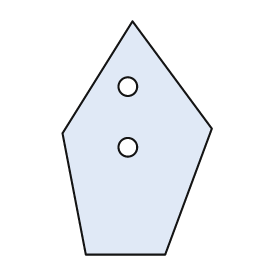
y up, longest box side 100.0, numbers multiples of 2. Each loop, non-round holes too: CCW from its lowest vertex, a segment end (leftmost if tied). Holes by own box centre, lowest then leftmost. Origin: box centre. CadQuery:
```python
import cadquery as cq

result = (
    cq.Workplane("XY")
    .moveTo(-22.0, -50.0)
    .lineTo(12.0, -50.0)
    .lineTo(32.0, 4.0)
    .lineTo(-2.0, 50.0)
    .lineTo(-32.0, 2.0)
    .close()
    .moveTo(-4.0, -4.0)
    .circle(4.0)
    .moveTo(-4.0, 22.0)
    .circle(4.0)
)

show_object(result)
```